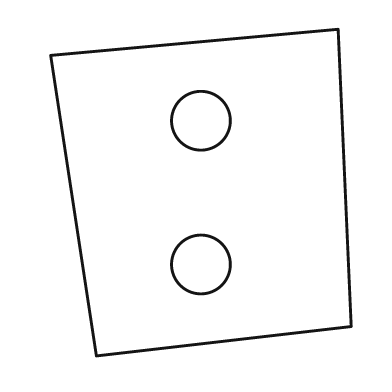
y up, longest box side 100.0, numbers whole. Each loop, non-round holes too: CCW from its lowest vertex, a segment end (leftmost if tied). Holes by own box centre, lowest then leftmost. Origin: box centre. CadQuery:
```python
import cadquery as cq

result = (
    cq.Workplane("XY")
    .moveTo(-32.0, -50.0)
    .lineTo(46.0, -41.0)
    .lineTo(42.0, 50.0)
    .lineTo(-46.0, 42.0)
    .close()
    .moveTo(0.0, -22.0)
    .circle(9.0)
    .moveTo(0.0, 22.0)
    .circle(9.0)
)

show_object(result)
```